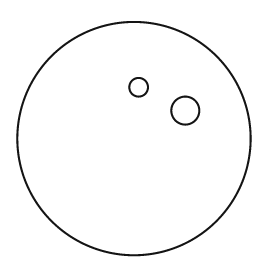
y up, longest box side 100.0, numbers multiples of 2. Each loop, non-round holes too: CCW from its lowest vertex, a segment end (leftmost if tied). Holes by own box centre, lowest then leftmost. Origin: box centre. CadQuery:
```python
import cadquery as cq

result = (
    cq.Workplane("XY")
    .moveTo(0.0, 0.0)
    .circle(50.0)
    .moveTo(22.0, 12.0)
    .circle(6.0)
    .moveTo(2.0, 22.0)
    .circle(4.0)
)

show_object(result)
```